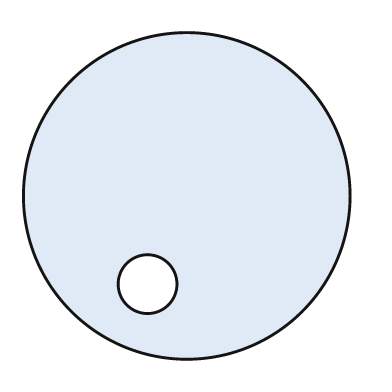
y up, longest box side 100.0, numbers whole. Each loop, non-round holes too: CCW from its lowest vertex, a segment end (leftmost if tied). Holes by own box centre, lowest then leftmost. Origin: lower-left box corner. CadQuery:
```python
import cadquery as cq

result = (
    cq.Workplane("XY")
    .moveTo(50.0, 50.0)
    .circle(50.0)
    .moveTo(38.0, 23.0)
    .circle(9.0)
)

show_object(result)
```